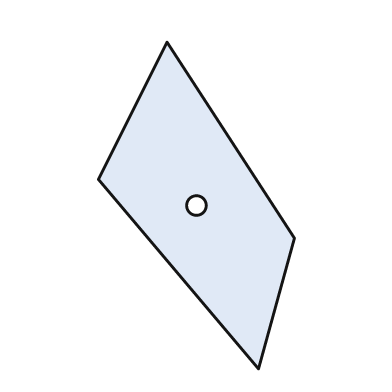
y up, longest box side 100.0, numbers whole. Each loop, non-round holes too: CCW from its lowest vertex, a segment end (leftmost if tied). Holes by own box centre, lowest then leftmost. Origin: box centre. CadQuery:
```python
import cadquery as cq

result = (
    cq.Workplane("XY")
    .moveTo(19.0, -50.0)
    .lineTo(30.0, -10.0)
    .lineTo(-9.0, 50.0)
    .lineTo(-30.0, 8.0)
    .close()
    .moveTo(0.0, 0.0)
    .circle(3.0)
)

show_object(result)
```